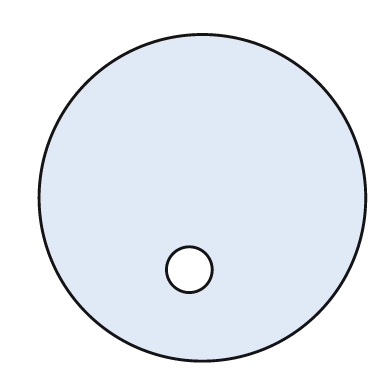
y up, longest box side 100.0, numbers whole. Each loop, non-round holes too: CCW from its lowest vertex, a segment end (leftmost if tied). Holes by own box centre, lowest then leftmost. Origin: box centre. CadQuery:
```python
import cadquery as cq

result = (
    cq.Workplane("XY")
    .moveTo(0.0, 0.0)
    .circle(50.0)
    .moveTo(-4.0, -22.0)
    .circle(7.0)
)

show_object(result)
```